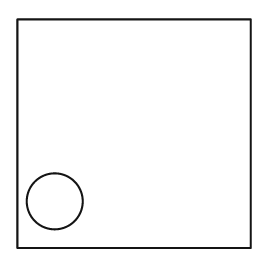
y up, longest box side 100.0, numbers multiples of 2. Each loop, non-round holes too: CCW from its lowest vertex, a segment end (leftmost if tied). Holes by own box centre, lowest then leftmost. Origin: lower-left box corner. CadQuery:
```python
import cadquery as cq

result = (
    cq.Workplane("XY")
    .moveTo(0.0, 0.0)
    .lineTo(100.0, 0.0)
    .lineTo(100.0, 98.0)
    .lineTo(0.0, 98.0)
    .close()
    .moveTo(16.0, 20.0)
    .circle(12.0)
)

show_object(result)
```